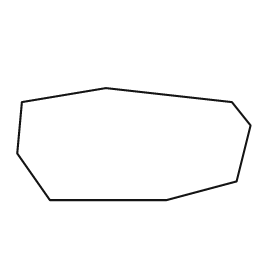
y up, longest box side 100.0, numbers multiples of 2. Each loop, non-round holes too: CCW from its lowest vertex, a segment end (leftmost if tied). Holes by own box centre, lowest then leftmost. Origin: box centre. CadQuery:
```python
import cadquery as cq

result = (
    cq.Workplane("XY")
    .moveTo(-36.0, -24.0)
    .lineTo(14.0, -24.0)
    .lineTo(44.0, -16.0)
    .lineTo(50.0, 8.0)
    .lineTo(42.0, 18.0)
    .lineTo(-12.0, 24.0)
    .lineTo(-48.0, 18.0)
    .lineTo(-50.0, -4.0)
    .close()
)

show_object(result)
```